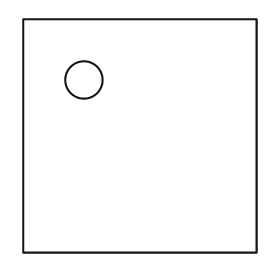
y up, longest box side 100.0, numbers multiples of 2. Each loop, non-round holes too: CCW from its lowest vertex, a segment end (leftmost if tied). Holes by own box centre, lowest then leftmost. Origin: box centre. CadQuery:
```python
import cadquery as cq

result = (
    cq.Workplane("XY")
    .moveTo(-50.0, -50.0)
    .lineTo(50.0, -50.0)
    .lineTo(50.0, 50.0)
    .lineTo(-50.0, 50.0)
    .close()
    .moveTo(-24.0, 24.0)
    .circle(8.0)
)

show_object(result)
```